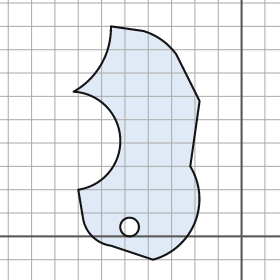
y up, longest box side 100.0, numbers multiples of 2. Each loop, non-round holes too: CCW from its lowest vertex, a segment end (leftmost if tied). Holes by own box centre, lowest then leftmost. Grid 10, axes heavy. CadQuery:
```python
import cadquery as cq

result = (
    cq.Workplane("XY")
    .moveTo(-38.0, -10.0)
    .threePointArc((-20.0, 6.0), (-22.0, 30.0))
    .lineTo(-18.0, 58.0)
    .lineTo(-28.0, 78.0)
    .threePointArc((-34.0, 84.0), (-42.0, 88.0))
    .lineTo(-56.0, 90.0)
    .threePointArc((-60.0, 74.0), (-72.0, 62.0))
    .threePointArc((-52.0, 42.0), (-70.0, 20.0))
    .lineTo(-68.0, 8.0)
    .threePointArc((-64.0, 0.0), (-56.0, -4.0))
    .close()
    .moveTo(-48.0, 4.0)
    .circle(4.0)
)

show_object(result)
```